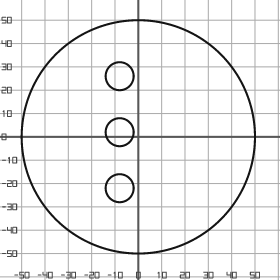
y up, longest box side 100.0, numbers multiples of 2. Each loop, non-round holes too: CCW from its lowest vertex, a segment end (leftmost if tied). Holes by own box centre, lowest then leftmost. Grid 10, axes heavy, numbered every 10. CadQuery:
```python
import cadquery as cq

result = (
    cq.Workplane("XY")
    .moveTo(0.0, 0.0)
    .circle(50.0)
    .moveTo(-8.0, -22.0)
    .circle(6.0)
    .moveTo(-8.0, 2.0)
    .circle(6.0)
    .moveTo(-8.0, 26.0)
    .circle(6.0)
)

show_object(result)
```